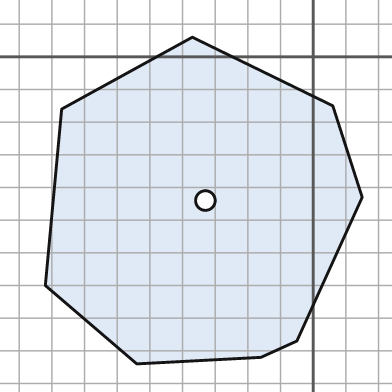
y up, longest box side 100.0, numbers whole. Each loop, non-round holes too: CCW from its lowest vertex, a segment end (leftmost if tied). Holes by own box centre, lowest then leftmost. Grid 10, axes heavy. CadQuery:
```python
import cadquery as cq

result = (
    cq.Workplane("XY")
    .moveTo(-54.0, -94.0)
    .lineTo(-16.0, -92.0)
    .lineTo(-5.0, -87.0)
    .lineTo(15.0, -43.0)
    .lineTo(6.0, -15.0)
    .lineTo(-37.0, 6.0)
    .lineTo(-77.0, -16.0)
    .lineTo(-82.0, -70.0)
    .close()
    .moveTo(-33.0, -44.0)
    .circle(3.0)
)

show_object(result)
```